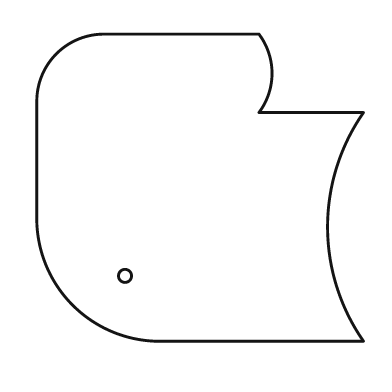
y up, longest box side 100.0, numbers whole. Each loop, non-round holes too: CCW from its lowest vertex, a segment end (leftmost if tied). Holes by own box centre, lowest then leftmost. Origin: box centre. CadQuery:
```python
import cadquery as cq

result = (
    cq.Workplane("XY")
    .moveTo(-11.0, -47.0)
    .lineTo(50.0, -47.0)
    .threePointArc((39.0, -12.0), (50.0, 23.0))
    .lineTo(18.0, 23.0)
    .threePointArc((22.0, 35.0), (18.0, 47.0))
    .lineTo(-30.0, 47.0)
    .threePointArc((-44.0, 41.0), (-50.0, 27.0))
    .lineTo(-50.0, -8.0)
    .threePointArc((-39.0, -36.0), (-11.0, -47.0))
    .close()
    .moveTo(-23.0, -27.0)
    .circle(2.0)
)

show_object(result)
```